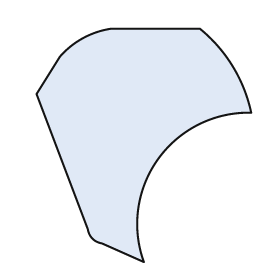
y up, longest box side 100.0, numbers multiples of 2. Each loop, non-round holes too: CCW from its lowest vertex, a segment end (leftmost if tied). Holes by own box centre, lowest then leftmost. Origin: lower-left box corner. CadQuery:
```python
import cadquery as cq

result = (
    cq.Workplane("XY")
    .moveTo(46.0, 0.0)
    .threePointArc((52.0, 44.0), (92.0, 64.0))
    .threePointArc((84.0, 84.0), (70.0, 100.0))
    .lineTo(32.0, 100.0)
    .threePointArc((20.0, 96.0), (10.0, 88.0))
    .lineTo(0.0, 72.0)
    .lineTo(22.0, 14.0)
    .threePointArc((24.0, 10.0), (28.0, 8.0))
    .close()
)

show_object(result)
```